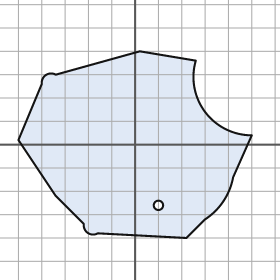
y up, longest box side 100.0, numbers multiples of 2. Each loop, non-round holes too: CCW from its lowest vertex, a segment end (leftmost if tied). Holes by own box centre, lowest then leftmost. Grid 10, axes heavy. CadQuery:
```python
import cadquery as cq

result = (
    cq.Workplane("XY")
    .moveTo(22.0, -40.0)
    .lineTo(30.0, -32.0)
    .threePointArc((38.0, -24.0), (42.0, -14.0))
    .lineTo(50.0, 4.0)
    .threePointArc((30.0, 14.0), (26.0, 36.0))
    .lineTo(2.0, 40.0)
    .lineTo(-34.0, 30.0)
    .threePointArc((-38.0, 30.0), (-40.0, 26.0))
    .lineTo(-50.0, 2.0)
    .lineTo(-34.0, -22.0)
    .lineTo(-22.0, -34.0)
    .threePointArc((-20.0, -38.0), (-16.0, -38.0))
    .close()
    .moveTo(10.0, -26.0)
    .circle(2.0)
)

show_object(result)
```